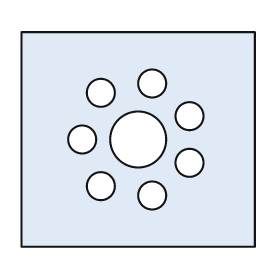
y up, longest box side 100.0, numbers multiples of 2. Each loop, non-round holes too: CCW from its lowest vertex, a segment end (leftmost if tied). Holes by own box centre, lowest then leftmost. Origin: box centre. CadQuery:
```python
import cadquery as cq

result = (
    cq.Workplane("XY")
    .moveTo(-50.0, -46.0)
    .lineTo(50.0, -46.0)
    .lineTo(50.0, 46.0)
    .lineTo(-50.0, 46.0)
    .close()
    .moveTo(6.0, -24.0)
    .circle(6.0)
    .moveTo(-16.0, -20.0)
    .circle(6.0)
    .moveTo(22.0, -10.0)
    .circle(6.0)
    .moveTo(-24.0, 0.0)
    .circle(6.0)
    .moveTo(0.0, 0.0)
    .circle(12.0)
    .moveTo(22.0, 10.0)
    .circle(6.0)
    .moveTo(-16.0, 20.0)
    .circle(6.0)
    .moveTo(6.0, 24.0)
    .circle(6.0)
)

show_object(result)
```